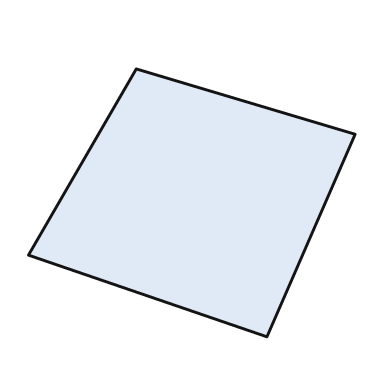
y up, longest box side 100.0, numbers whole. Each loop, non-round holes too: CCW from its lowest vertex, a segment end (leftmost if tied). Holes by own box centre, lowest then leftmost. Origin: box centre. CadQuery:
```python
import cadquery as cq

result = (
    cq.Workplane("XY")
    .moveTo(23.0, -41.0)
    .lineTo(50.0, 21.0)
    .lineTo(-17.0, 41.0)
    .lineTo(-50.0, -16.0)
    .close()
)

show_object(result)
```